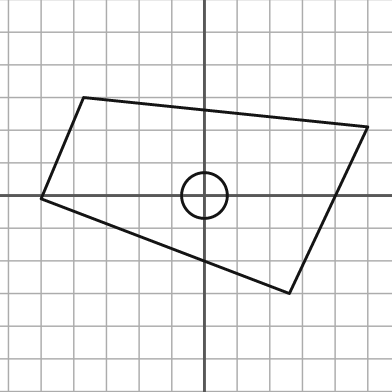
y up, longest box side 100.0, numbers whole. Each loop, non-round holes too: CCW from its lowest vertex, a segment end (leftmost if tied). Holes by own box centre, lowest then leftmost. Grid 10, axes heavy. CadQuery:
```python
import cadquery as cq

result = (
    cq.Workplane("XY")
    .moveTo(26.0, -30.0)
    .lineTo(50.0, 21.0)
    .lineTo(-37.0, 30.0)
    .lineTo(-50.0, -1.0)
    .close()
    .moveTo(0.0, 0.0)
    .circle(7.0)
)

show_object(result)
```